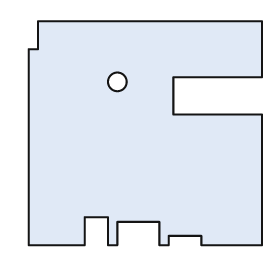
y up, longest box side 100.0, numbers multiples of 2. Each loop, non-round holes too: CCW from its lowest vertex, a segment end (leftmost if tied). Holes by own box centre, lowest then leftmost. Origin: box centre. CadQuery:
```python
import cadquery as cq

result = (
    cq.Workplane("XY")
    .moveTo(-50.0, -48.0)
    .lineTo(-26.0, -48.0)
    .lineTo(-26.0, -36.0)
    .lineTo(-16.0, -36.0)
    .lineTo(-16.0, -48.0)
    .lineTo(-12.0, -48.0)
    .lineTo(-12.0, -38.0)
    .lineTo(6.0, -38.0)
    .lineTo(6.0, -48.0)
    .lineTo(10.0, -48.0)
    .lineTo(10.0, -44.0)
    .lineTo(24.0, -44.0)
    .lineTo(24.0, -48.0)
    .lineTo(50.0, -48.0)
    .lineTo(50.0, 8.0)
    .lineTo(12.0, 8.0)
    .lineTo(12.0, 24.0)
    .lineTo(50.0, 24.0)
    .lineTo(50.0, 48.0)
    .lineTo(-46.0, 48.0)
    .lineTo(-46.0, 36.0)
    .lineTo(-50.0, 36.0)
    .close()
    .moveTo(-12.0, 22.0)
    .circle(4.0)
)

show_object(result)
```